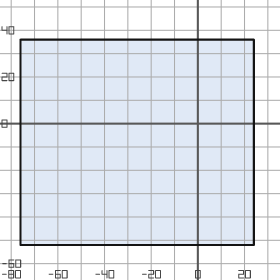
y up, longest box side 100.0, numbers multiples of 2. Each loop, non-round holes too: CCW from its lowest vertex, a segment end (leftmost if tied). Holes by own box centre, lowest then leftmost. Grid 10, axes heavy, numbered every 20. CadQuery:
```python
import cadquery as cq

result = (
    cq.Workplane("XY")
    .moveTo(-76.0, -52.0)
    .lineTo(24.0, -52.0)
    .lineTo(24.0, 36.0)
    .lineTo(-76.0, 36.0)
    .close()
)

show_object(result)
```